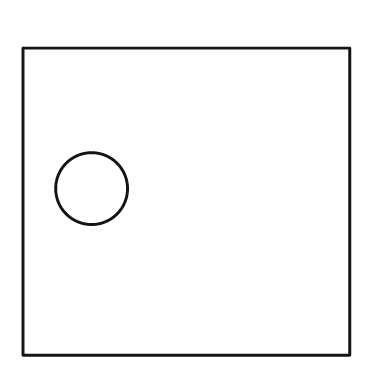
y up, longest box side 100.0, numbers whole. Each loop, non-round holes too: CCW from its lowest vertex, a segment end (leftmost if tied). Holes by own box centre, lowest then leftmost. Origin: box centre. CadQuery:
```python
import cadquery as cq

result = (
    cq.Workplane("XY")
    .moveTo(-50.0, -47.0)
    .lineTo(50.0, -47.0)
    .lineTo(50.0, 47.0)
    .lineTo(-50.0, 47.0)
    .close()
    .moveTo(-29.0, 4.0)
    .circle(11.0)
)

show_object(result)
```